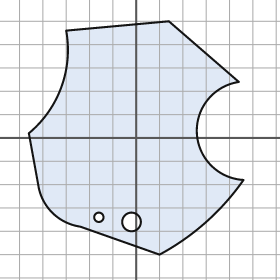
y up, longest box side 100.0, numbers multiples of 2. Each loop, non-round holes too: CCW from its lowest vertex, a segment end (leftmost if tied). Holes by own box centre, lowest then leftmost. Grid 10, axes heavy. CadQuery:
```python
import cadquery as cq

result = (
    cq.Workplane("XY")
    .moveTo(10.0, -50.0)
    .threePointArc((30.0, -36.0), (46.0, -18.0))
    .threePointArc((26.0, 2.0), (44.0, 24.0))
    .lineTo(14.0, 50.0)
    .lineTo(-30.0, 46.0)
    .threePointArc((-32.0, 22.0), (-46.0, 2.0))
    .lineTo(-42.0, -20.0)
    .threePointArc((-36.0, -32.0), (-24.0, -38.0))
    .close()
    .moveTo(-2.0, -36.0)
    .circle(4.0)
    .moveTo(-16.0, -34.0)
    .circle(2.0)
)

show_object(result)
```